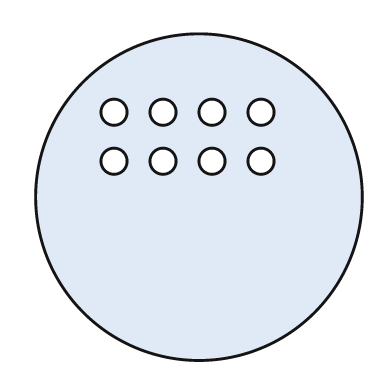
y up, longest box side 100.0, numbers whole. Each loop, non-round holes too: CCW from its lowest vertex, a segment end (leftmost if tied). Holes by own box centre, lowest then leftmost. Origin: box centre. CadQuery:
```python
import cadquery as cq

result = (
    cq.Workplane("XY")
    .moveTo(0.0, 0.0)
    .circle(50.0)
    .moveTo(-26.0, 11.0)
    .circle(4.0)
    .moveTo(-11.0, 11.0)
    .circle(4.0)
    .moveTo(4.0, 11.0)
    .circle(4.0)
    .moveTo(19.0, 11.0)
    .circle(4.0)
    .moveTo(-26.0, 26.0)
    .circle(4.0)
    .moveTo(-11.0, 26.0)
    .circle(4.0)
    .moveTo(4.0, 26.0)
    .circle(4.0)
    .moveTo(19.0, 26.0)
    .circle(4.0)
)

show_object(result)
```